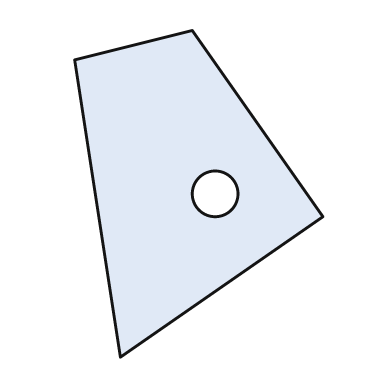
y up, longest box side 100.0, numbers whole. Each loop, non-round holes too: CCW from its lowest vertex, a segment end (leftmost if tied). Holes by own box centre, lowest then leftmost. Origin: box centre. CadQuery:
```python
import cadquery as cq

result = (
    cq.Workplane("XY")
    .moveTo(-24.0, -50.0)
    .lineTo(38.0, -7.0)
    .lineTo(-2.0, 50.0)
    .lineTo(-38.0, 41.0)
    .close()
    .moveTo(5.0, 0.0)
    .circle(7.0)
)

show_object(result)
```